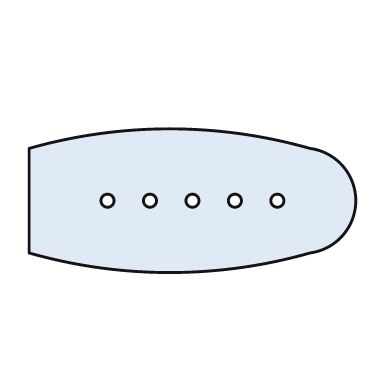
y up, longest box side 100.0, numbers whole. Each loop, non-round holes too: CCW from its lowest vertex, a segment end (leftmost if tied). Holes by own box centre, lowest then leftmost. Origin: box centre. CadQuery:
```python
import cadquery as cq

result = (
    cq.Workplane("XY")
    .moveTo(-50.0, -16.0)
    .threePointArc((-7.0, -22.0), (36.0, -16.0))
    .threePointArc((50.0, 0.0), (36.0, 16.0))
    .threePointArc((-7.0, 22.0), (-50.0, 16.0))
    .close()
    .moveTo(-26.0, 0.0)
    .circle(2.0)
    .moveTo(-13.0, 0.0)
    .circle(2.0)
    .moveTo(0.0, 0.0)
    .circle(2.0)
    .moveTo(13.0, 0.0)
    .circle(2.0)
    .moveTo(26.0, 0.0)
    .circle(2.0)
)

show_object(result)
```